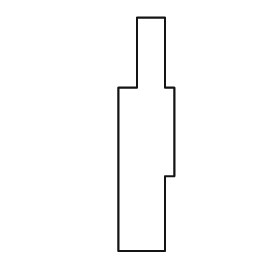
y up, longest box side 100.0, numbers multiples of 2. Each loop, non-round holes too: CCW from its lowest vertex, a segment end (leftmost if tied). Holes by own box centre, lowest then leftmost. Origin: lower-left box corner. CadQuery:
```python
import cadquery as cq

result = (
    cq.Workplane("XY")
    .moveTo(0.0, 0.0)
    .lineTo(20.0, 0.0)
    .lineTo(20.0, 32.0)
    .lineTo(24.0, 32.0)
    .lineTo(24.0, 70.0)
    .lineTo(20.0, 70.0)
    .lineTo(20.0, 100.0)
    .lineTo(8.0, 100.0)
    .lineTo(8.0, 70.0)
    .lineTo(0.0, 70.0)
    .close()
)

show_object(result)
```